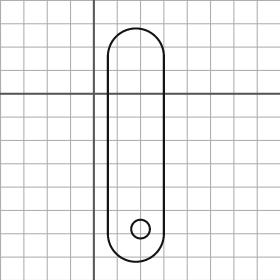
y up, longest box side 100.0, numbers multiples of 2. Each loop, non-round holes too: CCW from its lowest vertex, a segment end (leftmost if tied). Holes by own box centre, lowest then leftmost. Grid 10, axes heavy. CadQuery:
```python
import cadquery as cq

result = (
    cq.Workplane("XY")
    .moveTo(6.0, -60.0)
    .threePointArc((18.0, -72.0), (30.0, -60.0))
    .lineTo(30.0, 16.0)
    .threePointArc((18.0, 28.0), (6.0, 16.0))
    .close()
    .moveTo(20.0, -58.0)
    .circle(4.0)
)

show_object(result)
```